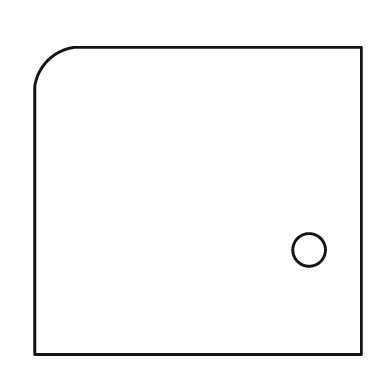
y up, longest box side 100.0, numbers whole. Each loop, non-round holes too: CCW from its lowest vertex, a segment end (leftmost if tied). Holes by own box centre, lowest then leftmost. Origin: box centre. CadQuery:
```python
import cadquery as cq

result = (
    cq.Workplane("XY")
    .moveTo(-50.0, -47.0)
    .lineTo(50.0, -47.0)
    .lineTo(50.0, 47.0)
    .lineTo(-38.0, 47.0)
    .threePointArc((-46.0, 43.0), (-50.0, 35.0))
    .close()
    .moveTo(34.0, -15.0)
    .circle(5.0)
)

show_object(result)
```